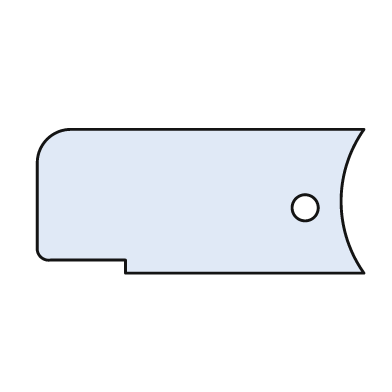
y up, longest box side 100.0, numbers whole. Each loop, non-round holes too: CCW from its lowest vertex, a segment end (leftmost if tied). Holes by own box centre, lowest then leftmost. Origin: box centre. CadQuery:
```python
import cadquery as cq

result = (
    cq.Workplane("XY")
    .moveTo(-23.0, -22.0)
    .lineTo(50.0, -22.0)
    .threePointArc((43.0, 0.0), (50.0, 22.0))
    .lineTo(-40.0, 22.0)
    .threePointArc((-47.0, 19.0), (-50.0, 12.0))
    .lineTo(-50.0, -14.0)
    .threePointArc((-49.0, -17.0), (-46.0, -18.0))
    .lineTo(-23.0, -18.0)
    .close()
    .moveTo(32.0, -2.0)
    .circle(4.0)
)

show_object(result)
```